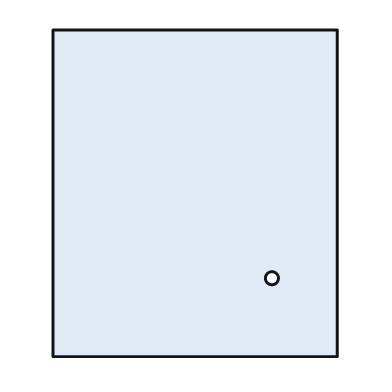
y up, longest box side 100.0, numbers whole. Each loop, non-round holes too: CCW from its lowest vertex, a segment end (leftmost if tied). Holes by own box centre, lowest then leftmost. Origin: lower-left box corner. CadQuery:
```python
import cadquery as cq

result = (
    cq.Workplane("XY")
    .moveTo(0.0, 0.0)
    .lineTo(87.0, 0.0)
    .lineTo(87.0, 100.0)
    .lineTo(0.0, 100.0)
    .close()
    .moveTo(67.0, 24.0)
    .circle(2.0)
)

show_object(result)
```